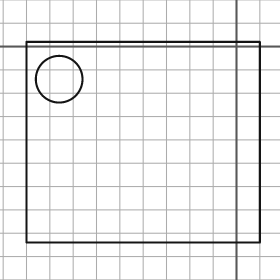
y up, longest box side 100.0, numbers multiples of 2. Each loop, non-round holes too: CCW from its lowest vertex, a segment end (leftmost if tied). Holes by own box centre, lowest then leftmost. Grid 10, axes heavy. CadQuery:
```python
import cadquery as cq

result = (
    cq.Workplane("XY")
    .moveTo(-90.0, -84.0)
    .lineTo(10.0, -84.0)
    .lineTo(10.0, 2.0)
    .lineTo(-90.0, 2.0)
    .close()
    .moveTo(-76.0, -14.0)
    .circle(10.0)
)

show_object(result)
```